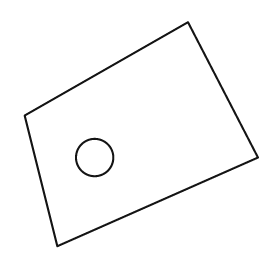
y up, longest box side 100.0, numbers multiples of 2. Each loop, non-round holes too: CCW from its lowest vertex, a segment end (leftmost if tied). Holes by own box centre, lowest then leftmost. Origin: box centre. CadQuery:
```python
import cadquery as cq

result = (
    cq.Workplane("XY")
    .moveTo(-36.0, -48.0)
    .lineTo(50.0, -10.0)
    .lineTo(20.0, 48.0)
    .lineTo(-50.0, 8.0)
    .close()
    .moveTo(-20.0, -10.0)
    .circle(8.0)
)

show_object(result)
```